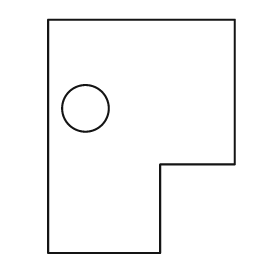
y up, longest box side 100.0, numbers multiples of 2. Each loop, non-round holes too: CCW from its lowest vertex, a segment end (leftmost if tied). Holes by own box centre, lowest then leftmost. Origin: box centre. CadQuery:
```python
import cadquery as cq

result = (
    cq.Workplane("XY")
    .moveTo(-40.0, -50.0)
    .lineTo(8.0, -50.0)
    .lineTo(8.0, -12.0)
    .lineTo(40.0, -12.0)
    .lineTo(40.0, 50.0)
    .lineTo(-40.0, 50.0)
    .close()
    .moveTo(-24.0, 12.0)
    .circle(10.0)
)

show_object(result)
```